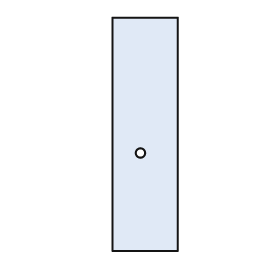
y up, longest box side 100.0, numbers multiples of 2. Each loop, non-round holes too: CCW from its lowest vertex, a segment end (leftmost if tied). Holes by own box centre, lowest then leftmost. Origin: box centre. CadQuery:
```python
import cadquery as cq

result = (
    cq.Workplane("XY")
    .moveTo(-14.0, -50.0)
    .lineTo(14.0, -50.0)
    .lineTo(14.0, 50.0)
    .lineTo(-14.0, 50.0)
    .close()
    .moveTo(-2.0, -8.0)
    .circle(2.0)
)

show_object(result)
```